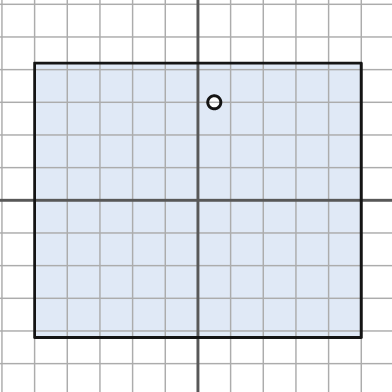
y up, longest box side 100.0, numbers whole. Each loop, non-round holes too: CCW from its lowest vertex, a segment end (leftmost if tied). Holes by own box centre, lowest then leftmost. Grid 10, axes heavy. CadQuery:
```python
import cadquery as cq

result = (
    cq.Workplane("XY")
    .moveTo(-50.0, -42.0)
    .lineTo(50.0, -42.0)
    .lineTo(50.0, 42.0)
    .lineTo(-50.0, 42.0)
    .close()
    .moveTo(5.0, 30.0)
    .circle(2.0)
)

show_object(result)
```